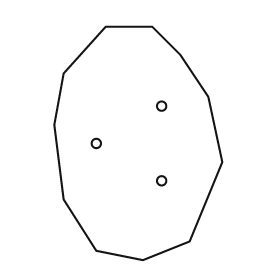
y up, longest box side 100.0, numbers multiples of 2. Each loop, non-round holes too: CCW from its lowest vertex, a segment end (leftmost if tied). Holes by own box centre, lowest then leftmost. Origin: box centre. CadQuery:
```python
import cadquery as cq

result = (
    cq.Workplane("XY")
    .moveTo(2.0, -50.0)
    .lineTo(22.0, -42.0)
    .lineTo(36.0, -8.0)
    .lineTo(30.0, 20.0)
    .lineTo(18.0, 38.0)
    .lineTo(6.0, 50.0)
    .lineTo(-14.0, 50.0)
    .lineTo(-32.0, 30.0)
    .lineTo(-36.0, 8.0)
    .lineTo(-32.0, -24.0)
    .lineTo(-18.0, -46.0)
    .close()
    .moveTo(10.0, -16.0)
    .circle(2.0)
    .moveTo(-18.0, 0.0)
    .circle(2.0)
    .moveTo(10.0, 16.0)
    .circle(2.0)
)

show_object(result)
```